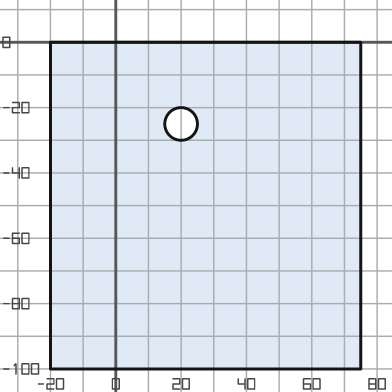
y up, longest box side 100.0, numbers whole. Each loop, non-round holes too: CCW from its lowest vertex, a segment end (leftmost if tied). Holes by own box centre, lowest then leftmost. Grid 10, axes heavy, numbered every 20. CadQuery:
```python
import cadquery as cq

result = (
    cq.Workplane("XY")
    .moveTo(-20.0, -100.0)
    .lineTo(75.0, -100.0)
    .lineTo(75.0, 0.0)
    .lineTo(-20.0, 0.0)
    .close()
    .moveTo(20.0, -25.0)
    .circle(5.0)
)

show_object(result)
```